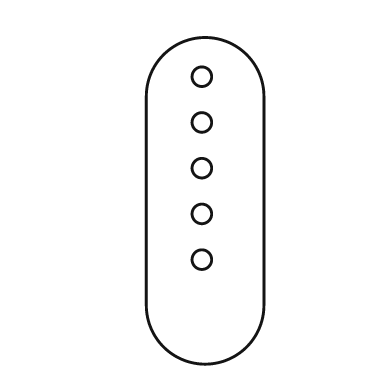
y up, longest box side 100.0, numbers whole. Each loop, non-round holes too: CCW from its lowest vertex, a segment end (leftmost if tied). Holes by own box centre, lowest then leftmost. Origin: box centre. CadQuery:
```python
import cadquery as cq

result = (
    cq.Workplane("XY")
    .moveTo(-18.0, -32.0)
    .threePointArc((0.0, -50.0), (18.0, -32.0))
    .lineTo(18.0, 32.0)
    .threePointArc((0.0, 50.0), (-18.0, 32.0))
    .close()
    .moveTo(-1.0, -18.0)
    .circle(3.0)
    .moveTo(-1.0, -4.0)
    .circle(3.0)
    .moveTo(-1.0, 10.0)
    .circle(3.0)
    .moveTo(-1.0, 24.0)
    .circle(3.0)
    .moveTo(-1.0, 38.0)
    .circle(3.0)
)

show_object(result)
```